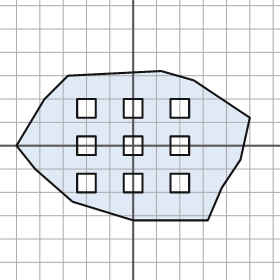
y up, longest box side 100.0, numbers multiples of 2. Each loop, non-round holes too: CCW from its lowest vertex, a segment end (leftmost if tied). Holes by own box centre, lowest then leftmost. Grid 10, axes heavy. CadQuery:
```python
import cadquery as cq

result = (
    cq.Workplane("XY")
    .moveTo(0.0, -32.0)
    .lineTo(32.0, -32.0)
    .lineTo(38.0, -18.0)
    .lineTo(46.0, -6.0)
    .lineTo(50.0, 12.0)
    .lineTo(26.0, 28.0)
    .lineTo(12.0, 32.0)
    .lineTo(-28.0, 30.0)
    .lineTo(-38.0, 20.0)
    .lineTo(-50.0, 0.0)
    .lineTo(-42.0, -10.0)
    .lineTo(-26.0, -24.0)
    .close()
    .moveTo(-24.0, -20.0)
    .lineTo(-16.0, -20.0)
    .lineTo(-16.0, -12.0)
    .lineTo(-24.0, -12.0)
    .close()
    .moveTo(-4.0, -20.0)
    .lineTo(4.0, -20.0)
    .lineTo(4.0, -12.0)
    .lineTo(-4.0, -12.0)
    .close()
    .moveTo(16.0, -20.0)
    .lineTo(24.0, -20.0)
    .lineTo(24.0, -12.0)
    .lineTo(16.0, -12.0)
    .close()
    .moveTo(-24.0, -4.0)
    .lineTo(-16.0, -4.0)
    .lineTo(-16.0, 4.0)
    .lineTo(-24.0, 4.0)
    .close()
    .moveTo(-4.0, -4.0)
    .lineTo(4.0, -4.0)
    .lineTo(4.0, 4.0)
    .lineTo(-4.0, 4.0)
    .close()
    .moveTo(16.0, -4.0)
    .lineTo(24.0, -4.0)
    .lineTo(24.0, 4.0)
    .lineTo(16.0, 4.0)
    .close()
    .moveTo(-24.0, 12.0)
    .lineTo(-16.0, 12.0)
    .lineTo(-16.0, 20.0)
    .lineTo(-24.0, 20.0)
    .close()
    .moveTo(-4.0, 12.0)
    .lineTo(4.0, 12.0)
    .lineTo(4.0, 20.0)
    .lineTo(-4.0, 20.0)
    .close()
    .moveTo(16.0, 12.0)
    .lineTo(24.0, 12.0)
    .lineTo(24.0, 20.0)
    .lineTo(16.0, 20.0)
    .close()
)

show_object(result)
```